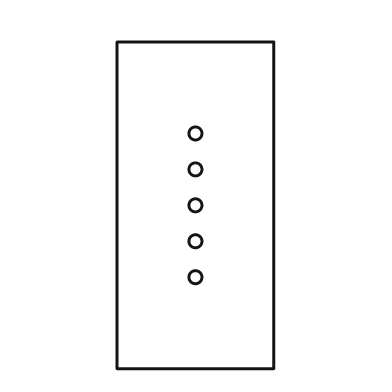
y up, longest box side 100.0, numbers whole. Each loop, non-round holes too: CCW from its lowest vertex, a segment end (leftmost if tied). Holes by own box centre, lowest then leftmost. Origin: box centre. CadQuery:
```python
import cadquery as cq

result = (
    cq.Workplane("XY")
    .moveTo(-24.0, -50.0)
    .lineTo(24.0, -50.0)
    .lineTo(24.0, 50.0)
    .lineTo(-24.0, 50.0)
    .close()
    .moveTo(0.0, -22.0)
    .circle(2.0)
    .moveTo(0.0, -11.0)
    .circle(2.0)
    .moveTo(0.0, 0.0)
    .circle(2.0)
    .moveTo(0.0, 11.0)
    .circle(2.0)
    .moveTo(0.0, 22.0)
    .circle(2.0)
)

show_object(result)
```